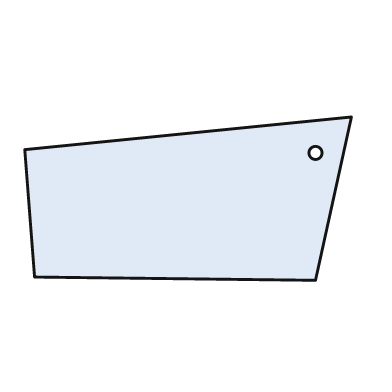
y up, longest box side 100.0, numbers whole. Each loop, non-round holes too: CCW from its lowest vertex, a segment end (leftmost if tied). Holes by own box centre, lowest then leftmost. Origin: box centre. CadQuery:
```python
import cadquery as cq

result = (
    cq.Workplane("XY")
    .moveTo(39.0, -25.0)
    .lineTo(50.0, 25.0)
    .lineTo(-50.0, 15.0)
    .lineTo(-47.0, -24.0)
    .close()
    .moveTo(39.0, 14.0)
    .circle(2.0)
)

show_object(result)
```